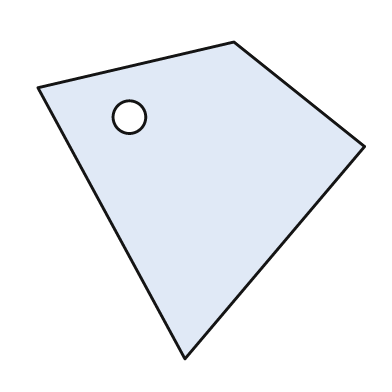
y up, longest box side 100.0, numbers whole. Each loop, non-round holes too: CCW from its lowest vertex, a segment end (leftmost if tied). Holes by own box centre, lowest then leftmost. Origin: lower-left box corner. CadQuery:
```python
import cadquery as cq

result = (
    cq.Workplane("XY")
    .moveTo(45.0, 0.0)
    .lineTo(100.0, 65.0)
    .lineTo(60.0, 97.0)
    .lineTo(0.0, 83.0)
    .close()
    .moveTo(28.0, 74.0)
    .circle(5.0)
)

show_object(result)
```